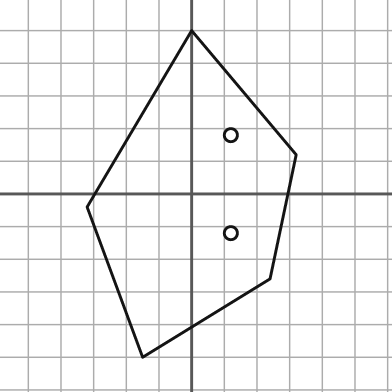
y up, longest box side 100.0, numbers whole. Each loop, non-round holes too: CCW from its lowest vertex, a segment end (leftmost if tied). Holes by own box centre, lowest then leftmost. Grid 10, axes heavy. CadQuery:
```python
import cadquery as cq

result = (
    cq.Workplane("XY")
    .moveTo(-15.0, -50.0)
    .lineTo(24.0, -26.0)
    .lineTo(32.0, 12.0)
    .lineTo(0.0, 50.0)
    .lineTo(-32.0, -4.0)
    .close()
    .moveTo(12.0, -12.0)
    .circle(2.0)
    .moveTo(12.0, 18.0)
    .circle(2.0)
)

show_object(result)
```